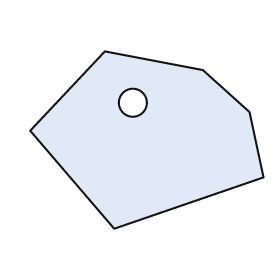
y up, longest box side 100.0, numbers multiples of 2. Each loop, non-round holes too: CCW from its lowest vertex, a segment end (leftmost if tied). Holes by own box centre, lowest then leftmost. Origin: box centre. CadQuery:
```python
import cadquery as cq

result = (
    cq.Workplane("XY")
    .moveTo(-14.0, -38.0)
    .lineTo(50.0, -16.0)
    .lineTo(44.0, 12.0)
    .lineTo(24.0, 30.0)
    .lineTo(-18.0, 38.0)
    .lineTo(-50.0, 4.0)
    .close()
    .moveTo(-6.0, 16.0)
    .circle(6.0)
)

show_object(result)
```